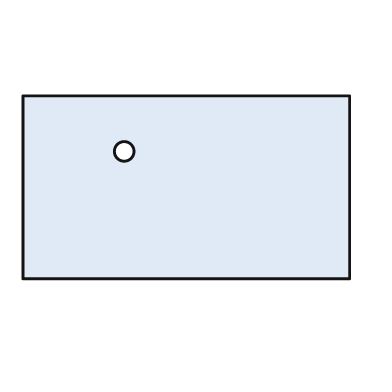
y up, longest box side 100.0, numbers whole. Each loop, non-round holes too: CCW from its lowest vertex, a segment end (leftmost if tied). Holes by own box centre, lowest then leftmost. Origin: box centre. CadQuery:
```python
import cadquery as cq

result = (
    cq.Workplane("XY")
    .moveTo(-50.0, -28.0)
    .lineTo(50.0, -28.0)
    .lineTo(50.0, 28.0)
    .lineTo(-50.0, 28.0)
    .close()
    .moveTo(-19.0, 11.0)
    .circle(3.0)
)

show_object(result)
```